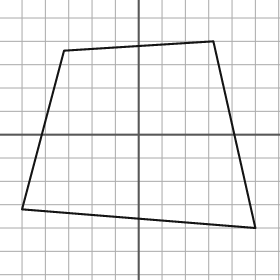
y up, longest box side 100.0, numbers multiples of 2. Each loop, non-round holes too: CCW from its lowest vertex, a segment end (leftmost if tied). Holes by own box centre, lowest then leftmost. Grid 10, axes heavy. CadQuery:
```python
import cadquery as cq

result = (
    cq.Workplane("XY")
    .moveTo(50.0, -40.0)
    .lineTo(32.0, 40.0)
    .lineTo(-32.0, 36.0)
    .lineTo(-50.0, -32.0)
    .close()
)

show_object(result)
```